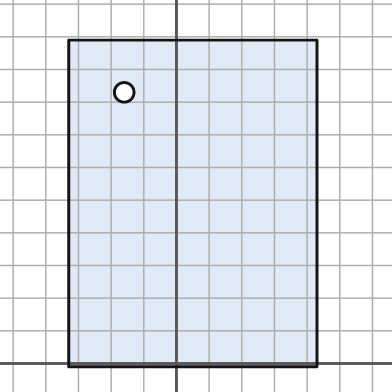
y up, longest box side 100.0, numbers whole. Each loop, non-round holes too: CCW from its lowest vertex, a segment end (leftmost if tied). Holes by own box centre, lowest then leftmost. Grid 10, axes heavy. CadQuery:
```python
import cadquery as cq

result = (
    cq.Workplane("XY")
    .moveTo(-33.0, -1.0)
    .lineTo(43.0, -1.0)
    .lineTo(43.0, 99.0)
    .lineTo(-33.0, 99.0)
    .close()
    .moveTo(-16.0, 83.0)
    .circle(3.0)
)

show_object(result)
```